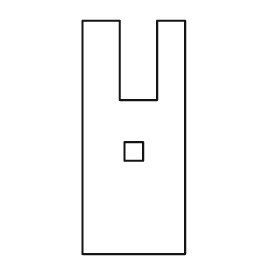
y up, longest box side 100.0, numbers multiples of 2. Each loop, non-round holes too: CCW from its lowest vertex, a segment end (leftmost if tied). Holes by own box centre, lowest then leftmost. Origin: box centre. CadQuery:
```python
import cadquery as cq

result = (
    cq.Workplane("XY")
    .moveTo(-22.0, -50.0)
    .lineTo(22.0, -50.0)
    .lineTo(22.0, 50.0)
    .lineTo(10.0, 50.0)
    .lineTo(10.0, 16.0)
    .lineTo(-6.0, 16.0)
    .lineTo(-6.0, 50.0)
    .lineTo(-22.0, 50.0)
    .close()
    .moveTo(-4.0, -10.0)
    .lineTo(4.0, -10.0)
    .lineTo(4.0, -2.0)
    .lineTo(-4.0, -2.0)
    .close()
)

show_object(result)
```